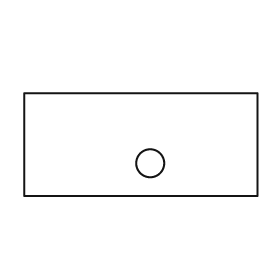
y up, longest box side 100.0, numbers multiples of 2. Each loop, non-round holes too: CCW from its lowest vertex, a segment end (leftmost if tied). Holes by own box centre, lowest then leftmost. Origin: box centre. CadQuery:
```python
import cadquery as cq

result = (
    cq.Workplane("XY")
    .moveTo(-50.0, -22.0)
    .lineTo(50.0, -22.0)
    .lineTo(50.0, 22.0)
    .lineTo(-50.0, 22.0)
    .close()
    .moveTo(4.0, -8.0)
    .circle(6.0)
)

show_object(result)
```